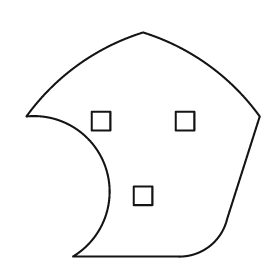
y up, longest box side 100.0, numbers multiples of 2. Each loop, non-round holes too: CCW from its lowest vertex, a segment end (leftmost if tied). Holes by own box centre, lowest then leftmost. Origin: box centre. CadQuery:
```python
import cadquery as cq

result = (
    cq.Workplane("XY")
    .moveTo(-30.0, -48.0)
    .lineTo(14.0, -48.0)
    .threePointArc((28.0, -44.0), (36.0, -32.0))
    .lineTo(50.0, 12.0)
    .threePointArc((28.0, 34.0), (0.0, 48.0))
    .threePointArc((-28.0, 34.0), (-50.0, 12.0))
    .threePointArc((-16.0, -10.0), (-30.0, -48.0))
    .close()
    .moveTo(-4.0, -26.0)
    .lineTo(4.0, -26.0)
    .lineTo(4.0, -18.0)
    .lineTo(-4.0, -18.0)
    .close()
    .moveTo(-22.0, 6.0)
    .lineTo(-14.0, 6.0)
    .lineTo(-14.0, 14.0)
    .lineTo(-22.0, 14.0)
    .close()
    .moveTo(14.0, 6.0)
    .lineTo(22.0, 6.0)
    .lineTo(22.0, 14.0)
    .lineTo(14.0, 14.0)
    .close()
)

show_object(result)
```